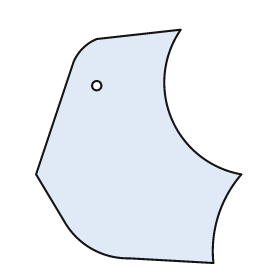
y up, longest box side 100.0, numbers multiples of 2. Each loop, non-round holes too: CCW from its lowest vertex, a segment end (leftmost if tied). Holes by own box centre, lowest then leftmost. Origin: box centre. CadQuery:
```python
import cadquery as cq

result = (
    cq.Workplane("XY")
    .moveTo(32.0, -50.0)
    .threePointArc((34.0, -30.0), (44.0, -12.0))
    .threePointArc((14.0, 12.0), (18.0, 50.0))
    .lineTo(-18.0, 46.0)
    .threePointArc((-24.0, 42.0), (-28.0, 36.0))
    .lineTo(-44.0, -12.0)
    .lineTo(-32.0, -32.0)
    .threePointArc((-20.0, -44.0), (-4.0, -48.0))
    .close()
    .moveTo(-18.0, 26.0)
    .circle(2.0)
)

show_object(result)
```